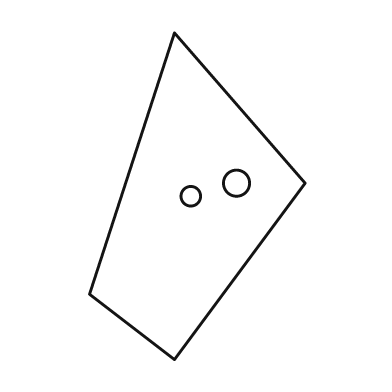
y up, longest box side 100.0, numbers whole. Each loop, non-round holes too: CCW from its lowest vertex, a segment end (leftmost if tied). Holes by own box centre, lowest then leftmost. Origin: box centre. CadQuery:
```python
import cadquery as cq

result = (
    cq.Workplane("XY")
    .moveTo(-7.0, -50.0)
    .lineTo(33.0, 4.0)
    .lineTo(-7.0, 50.0)
    .lineTo(-33.0, -30.0)
    .close()
    .moveTo(-2.0, 0.0)
    .circle(3.0)
    .moveTo(12.0, 4.0)
    .circle(4.0)
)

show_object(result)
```